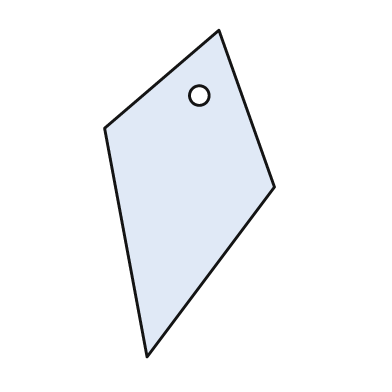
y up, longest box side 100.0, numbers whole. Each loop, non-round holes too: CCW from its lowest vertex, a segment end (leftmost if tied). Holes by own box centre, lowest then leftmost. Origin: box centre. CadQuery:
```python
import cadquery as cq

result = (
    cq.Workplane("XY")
    .moveTo(-13.0, -50.0)
    .lineTo(26.0, 2.0)
    .lineTo(9.0, 50.0)
    .lineTo(-26.0, 20.0)
    .close()
    .moveTo(3.0, 30.0)
    .circle(3.0)
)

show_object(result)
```